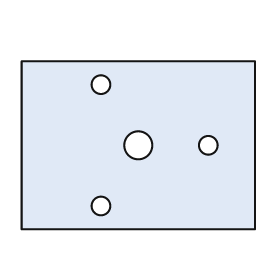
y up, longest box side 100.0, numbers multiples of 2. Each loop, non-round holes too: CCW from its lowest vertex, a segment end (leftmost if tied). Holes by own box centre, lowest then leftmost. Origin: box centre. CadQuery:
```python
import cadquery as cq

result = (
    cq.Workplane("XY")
    .moveTo(-50.0, -36.0)
    .lineTo(50.0, -36.0)
    .lineTo(50.0, 36.0)
    .lineTo(-50.0, 36.0)
    .close()
    .moveTo(-16.0, -26.0)
    .circle(4.0)
    .moveTo(0.0, 0.0)
    .circle(6.0)
    .moveTo(30.0, 0.0)
    .circle(4.0)
    .moveTo(-16.0, 26.0)
    .circle(4.0)
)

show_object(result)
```